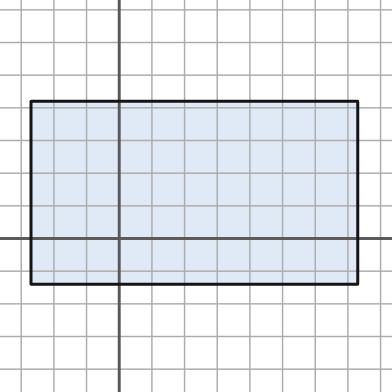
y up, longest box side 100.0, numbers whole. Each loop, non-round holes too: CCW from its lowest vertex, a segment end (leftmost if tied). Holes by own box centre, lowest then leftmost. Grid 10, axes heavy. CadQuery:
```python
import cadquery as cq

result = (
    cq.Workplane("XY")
    .moveTo(-27.0, -14.0)
    .lineTo(73.0, -14.0)
    .lineTo(73.0, 42.0)
    .lineTo(-27.0, 42.0)
    .close()
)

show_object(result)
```